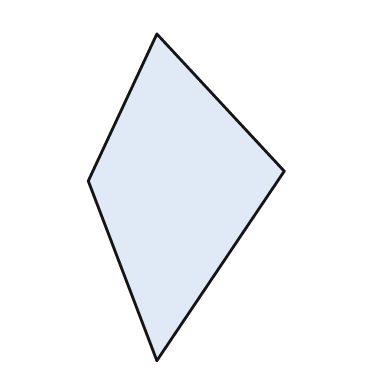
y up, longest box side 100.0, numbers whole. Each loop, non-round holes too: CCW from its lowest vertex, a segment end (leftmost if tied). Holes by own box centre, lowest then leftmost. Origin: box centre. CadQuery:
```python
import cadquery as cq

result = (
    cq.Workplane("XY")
    .moveTo(-9.0, -50.0)
    .lineTo(30.0, 8.0)
    .lineTo(-9.0, 50.0)
    .lineTo(-30.0, 5.0)
    .close()
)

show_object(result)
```